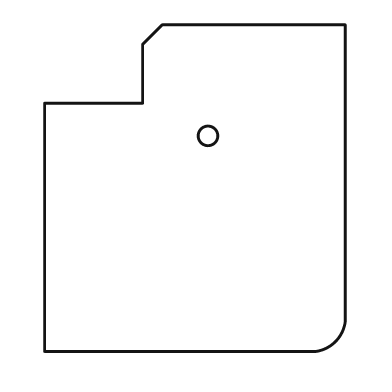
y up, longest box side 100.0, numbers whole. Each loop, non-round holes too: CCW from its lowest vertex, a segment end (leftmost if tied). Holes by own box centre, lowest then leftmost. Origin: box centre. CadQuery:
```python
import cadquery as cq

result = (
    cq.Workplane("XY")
    .moveTo(-46.0, -50.0)
    .lineTo(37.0, -50.0)
    .threePointArc((43.0, -47.0), (46.0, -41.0))
    .lineTo(46.0, 50.0)
    .lineTo(-10.0, 50.0)
    .lineTo(-16.0, 44.0)
    .lineTo(-16.0, 26.0)
    .lineTo(-46.0, 26.0)
    .close()
    .moveTo(4.0, 16.0)
    .circle(3.0)
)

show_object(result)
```